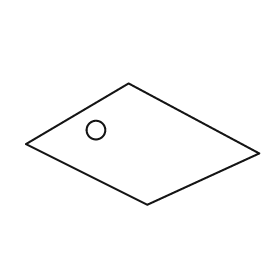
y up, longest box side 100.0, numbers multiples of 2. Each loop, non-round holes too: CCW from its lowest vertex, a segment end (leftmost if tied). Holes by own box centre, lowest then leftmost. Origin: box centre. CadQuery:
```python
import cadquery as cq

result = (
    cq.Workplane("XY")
    .moveTo(2.0, -26.0)
    .lineTo(50.0, -4.0)
    .lineTo(-6.0, 26.0)
    .lineTo(-50.0, 0.0)
    .close()
    .moveTo(-20.0, 6.0)
    .circle(4.0)
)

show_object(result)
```